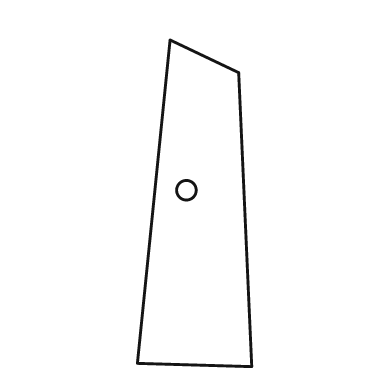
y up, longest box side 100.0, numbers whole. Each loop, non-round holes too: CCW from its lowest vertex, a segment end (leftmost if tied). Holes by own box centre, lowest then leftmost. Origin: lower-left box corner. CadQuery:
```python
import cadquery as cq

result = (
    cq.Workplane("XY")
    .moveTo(35.0, 0.0)
    .lineTo(31.0, 90.0)
    .lineTo(10.0, 100.0)
    .lineTo(0.0, 1.0)
    .close()
    .moveTo(15.0, 54.0)
    .circle(3.0)
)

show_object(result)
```